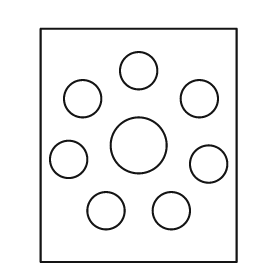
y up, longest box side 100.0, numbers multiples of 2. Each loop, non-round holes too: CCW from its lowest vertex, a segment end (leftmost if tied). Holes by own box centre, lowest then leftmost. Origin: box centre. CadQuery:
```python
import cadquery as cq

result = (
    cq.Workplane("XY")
    .moveTo(-42.0, -50.0)
    .lineTo(42.0, -50.0)
    .lineTo(42.0, 50.0)
    .lineTo(-42.0, 50.0)
    .close()
    .moveTo(-14.0, -28.0)
    .circle(8.0)
    .moveTo(14.0, -28.0)
    .circle(8.0)
    .moveTo(30.0, -8.0)
    .circle(8.0)
    .moveTo(-30.0, -6.0)
    .circle(8.0)
    .moveTo(0.0, 0.0)
    .circle(12.0)
    .moveTo(-24.0, 20.0)
    .circle(8.0)
    .moveTo(26.0, 20.0)
    .circle(8.0)
    .moveTo(0.0, 32.0)
    .circle(8.0)
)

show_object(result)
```